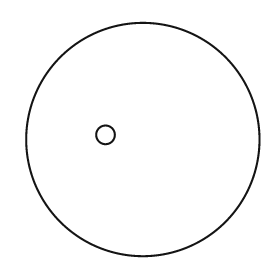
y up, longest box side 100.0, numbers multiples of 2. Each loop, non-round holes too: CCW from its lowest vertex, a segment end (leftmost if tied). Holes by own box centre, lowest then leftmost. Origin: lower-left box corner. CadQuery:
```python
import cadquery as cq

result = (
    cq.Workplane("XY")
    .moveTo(50.0, 50.0)
    .circle(50.0)
    .moveTo(34.0, 52.0)
    .circle(4.0)
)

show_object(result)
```